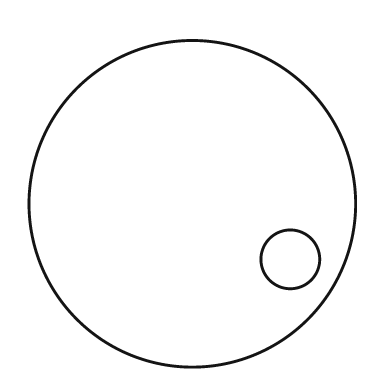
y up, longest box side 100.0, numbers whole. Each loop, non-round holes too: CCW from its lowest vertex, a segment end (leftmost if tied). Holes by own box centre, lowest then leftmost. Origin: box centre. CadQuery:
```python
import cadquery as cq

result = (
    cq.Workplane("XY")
    .moveTo(0.0, 0.0)
    .circle(50.0)
    .moveTo(30.0, -17.0)
    .circle(9.0)
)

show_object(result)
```